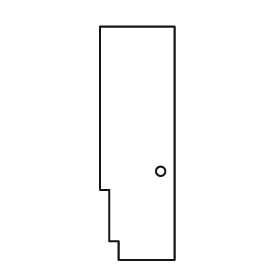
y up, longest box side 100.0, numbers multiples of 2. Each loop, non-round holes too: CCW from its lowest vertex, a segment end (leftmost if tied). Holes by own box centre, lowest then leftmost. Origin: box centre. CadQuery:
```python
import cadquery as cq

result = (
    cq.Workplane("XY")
    .moveTo(-8.0, -50.0)
    .lineTo(16.0, -50.0)
    .lineTo(16.0, 50.0)
    .lineTo(-16.0, 50.0)
    .lineTo(-16.0, -20.0)
    .lineTo(-12.0, -20.0)
    .lineTo(-12.0, -42.0)
    .lineTo(-8.0, -42.0)
    .close()
    .moveTo(10.0, -12.0)
    .circle(2.0)
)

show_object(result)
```